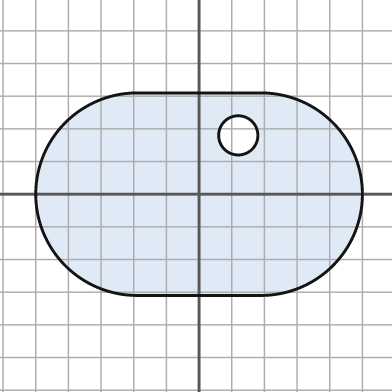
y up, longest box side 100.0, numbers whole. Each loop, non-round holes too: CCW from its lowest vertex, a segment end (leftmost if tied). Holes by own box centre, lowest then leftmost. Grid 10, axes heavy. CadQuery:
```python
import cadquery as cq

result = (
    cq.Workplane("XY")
    .moveTo(-19.0, -31.0)
    .lineTo(19.0, -31.0)
    .threePointArc((50.0, 0.0), (19.0, 31.0))
    .lineTo(-19.0, 31.0)
    .threePointArc((-50.0, 0.0), (-19.0, -31.0))
    .close()
    .moveTo(12.0, 18.0)
    .circle(6.0)
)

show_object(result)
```